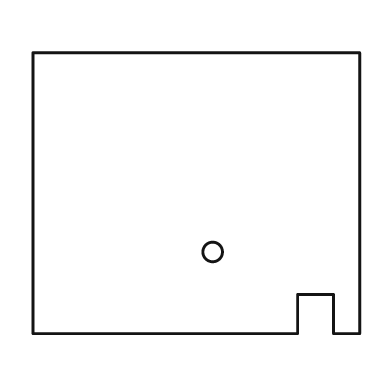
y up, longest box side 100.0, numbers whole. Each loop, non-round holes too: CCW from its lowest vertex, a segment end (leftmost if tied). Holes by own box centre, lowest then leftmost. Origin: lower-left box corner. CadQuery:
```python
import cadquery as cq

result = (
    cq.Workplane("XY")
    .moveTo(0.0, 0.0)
    .lineTo(81.0, 0.0)
    .lineTo(81.0, 12.0)
    .lineTo(92.0, 12.0)
    .lineTo(92.0, 0.0)
    .lineTo(100.0, 0.0)
    .lineTo(100.0, 86.0)
    .lineTo(0.0, 86.0)
    .close()
    .moveTo(55.0, 25.0)
    .circle(3.0)
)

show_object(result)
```